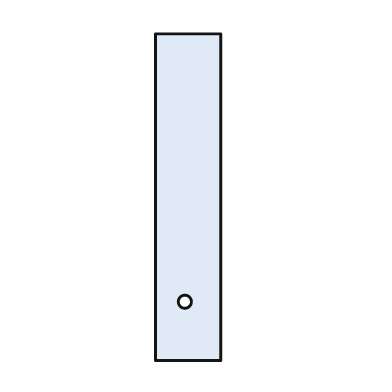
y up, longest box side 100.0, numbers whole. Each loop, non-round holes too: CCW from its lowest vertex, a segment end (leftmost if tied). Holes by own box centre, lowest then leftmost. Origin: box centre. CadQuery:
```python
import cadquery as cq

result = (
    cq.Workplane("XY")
    .moveTo(-10.0, -50.0)
    .lineTo(10.0, -50.0)
    .lineTo(10.0, 50.0)
    .lineTo(-10.0, 50.0)
    .close()
    .moveTo(-1.0, -32.0)
    .circle(2.0)
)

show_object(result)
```